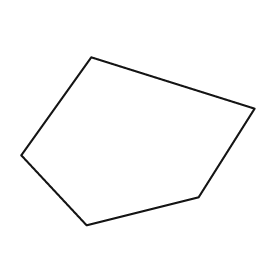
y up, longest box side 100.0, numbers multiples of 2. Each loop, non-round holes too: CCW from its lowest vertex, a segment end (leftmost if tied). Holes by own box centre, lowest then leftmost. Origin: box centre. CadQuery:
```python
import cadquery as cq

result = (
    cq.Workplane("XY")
    .moveTo(-22.0, -36.0)
    .lineTo(26.0, -24.0)
    .lineTo(50.0, 14.0)
    .lineTo(-20.0, 36.0)
    .lineTo(-50.0, -6.0)
    .close()
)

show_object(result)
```